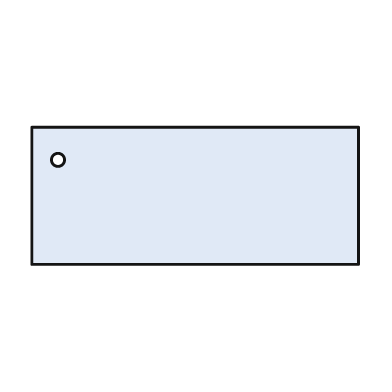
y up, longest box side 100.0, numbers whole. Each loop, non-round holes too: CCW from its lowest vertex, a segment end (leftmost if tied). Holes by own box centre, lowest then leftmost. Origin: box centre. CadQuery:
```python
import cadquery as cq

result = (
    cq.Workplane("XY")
    .moveTo(-50.0, -21.0)
    .lineTo(50.0, -21.0)
    .lineTo(50.0, 21.0)
    .lineTo(-50.0, 21.0)
    .close()
    .moveTo(-42.0, 11.0)
    .circle(2.0)
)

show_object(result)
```